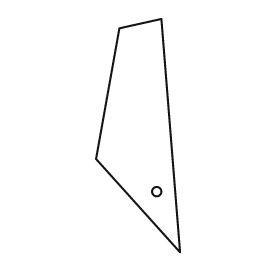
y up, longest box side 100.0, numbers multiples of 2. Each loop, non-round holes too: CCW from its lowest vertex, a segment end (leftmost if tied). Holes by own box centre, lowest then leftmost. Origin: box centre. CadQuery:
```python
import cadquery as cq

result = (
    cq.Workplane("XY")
    .moveTo(18.0, -50.0)
    .lineTo(10.0, 50.0)
    .lineTo(-8.0, 46.0)
    .lineTo(-18.0, -10.0)
    .close()
    .moveTo(8.0, -24.0)
    .circle(2.0)
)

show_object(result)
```